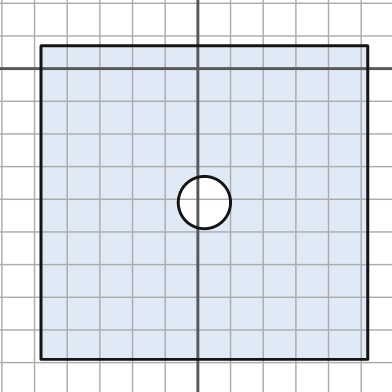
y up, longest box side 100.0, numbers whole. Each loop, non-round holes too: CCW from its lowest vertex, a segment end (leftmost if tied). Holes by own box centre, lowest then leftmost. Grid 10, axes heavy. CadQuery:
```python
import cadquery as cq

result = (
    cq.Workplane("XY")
    .moveTo(-48.0, -89.0)
    .lineTo(52.0, -89.0)
    .lineTo(52.0, 7.0)
    .lineTo(-48.0, 7.0)
    .close()
    .moveTo(2.0, -41.0)
    .circle(8.0)
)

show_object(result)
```